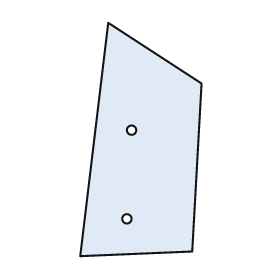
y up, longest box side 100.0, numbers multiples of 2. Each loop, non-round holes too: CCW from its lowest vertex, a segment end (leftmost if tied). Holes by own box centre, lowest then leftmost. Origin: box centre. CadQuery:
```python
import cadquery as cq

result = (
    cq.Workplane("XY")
    .moveTo(-26.0, -50.0)
    .lineTo(22.0, -48.0)
    .lineTo(26.0, 24.0)
    .lineTo(-14.0, 50.0)
    .close()
    .moveTo(-6.0, -34.0)
    .circle(2.0)
    .moveTo(-4.0, 4.0)
    .circle(2.0)
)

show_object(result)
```